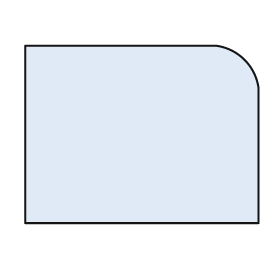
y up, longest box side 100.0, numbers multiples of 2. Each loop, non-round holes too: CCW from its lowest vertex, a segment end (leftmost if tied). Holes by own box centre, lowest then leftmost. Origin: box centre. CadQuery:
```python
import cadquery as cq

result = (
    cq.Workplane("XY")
    .moveTo(-50.0, -38.0)
    .lineTo(50.0, -38.0)
    .lineTo(50.0, 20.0)
    .threePointArc((44.0, 32.0), (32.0, 38.0))
    .lineTo(-50.0, 38.0)
    .close()
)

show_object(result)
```